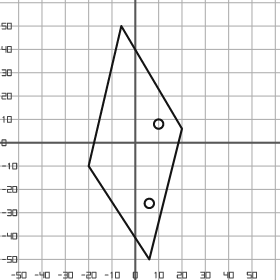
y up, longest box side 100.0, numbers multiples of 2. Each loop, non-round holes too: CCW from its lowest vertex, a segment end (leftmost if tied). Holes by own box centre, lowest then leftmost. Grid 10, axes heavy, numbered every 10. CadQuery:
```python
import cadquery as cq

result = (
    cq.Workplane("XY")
    .moveTo(6.0, -50.0)
    .lineTo(20.0, 6.0)
    .lineTo(-6.0, 50.0)
    .lineTo(-20.0, -10.0)
    .close()
    .moveTo(6.0, -26.0)
    .circle(2.0)
    .moveTo(10.0, 8.0)
    .circle(2.0)
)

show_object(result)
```